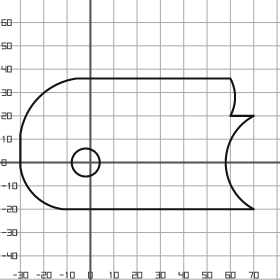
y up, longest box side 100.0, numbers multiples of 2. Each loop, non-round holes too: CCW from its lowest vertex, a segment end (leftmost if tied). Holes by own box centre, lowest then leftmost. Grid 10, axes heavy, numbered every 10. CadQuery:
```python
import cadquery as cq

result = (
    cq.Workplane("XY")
    .moveTo(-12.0, -20.0)
    .lineTo(70.0, -20.0)
    .threePointArc((58.0, 0.0), (70.0, 20.0))
    .lineTo(60.0, 20.0)
    .threePointArc((62.0, 28.0), (60.0, 36.0))
    .lineTo(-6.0, 36.0)
    .threePointArc((-22.0, 28.0), (-30.0, 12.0))
    .lineTo(-30.0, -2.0)
    .threePointArc((-24.0, -14.0), (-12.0, -20.0))
    .close()
    .moveTo(-2.0, 0.0)
    .circle(6.0)
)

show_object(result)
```